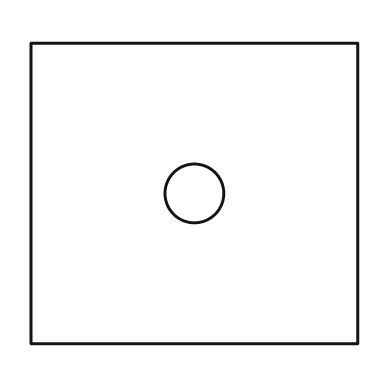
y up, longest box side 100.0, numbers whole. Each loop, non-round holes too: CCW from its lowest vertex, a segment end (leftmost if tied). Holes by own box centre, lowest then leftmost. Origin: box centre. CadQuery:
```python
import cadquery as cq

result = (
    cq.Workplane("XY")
    .moveTo(-50.0, -46.0)
    .lineTo(50.0, -46.0)
    .lineTo(50.0, 46.0)
    .lineTo(-50.0, 46.0)
    .close()
    .moveTo(0.0, 0.0)
    .circle(9.0)
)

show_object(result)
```